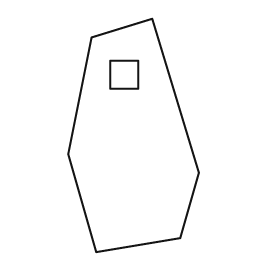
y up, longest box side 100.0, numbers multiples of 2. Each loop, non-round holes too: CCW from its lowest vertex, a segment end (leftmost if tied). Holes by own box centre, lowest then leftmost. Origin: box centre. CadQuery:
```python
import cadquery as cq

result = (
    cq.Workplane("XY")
    .moveTo(-16.0, -50.0)
    .lineTo(20.0, -44.0)
    .lineTo(28.0, -16.0)
    .lineTo(8.0, 50.0)
    .lineTo(-18.0, 42.0)
    .lineTo(-28.0, -8.0)
    .close()
    .moveTo(-10.0, 20.0)
    .lineTo(2.0, 20.0)
    .lineTo(2.0, 32.0)
    .lineTo(-10.0, 32.0)
    .close()
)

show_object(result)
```